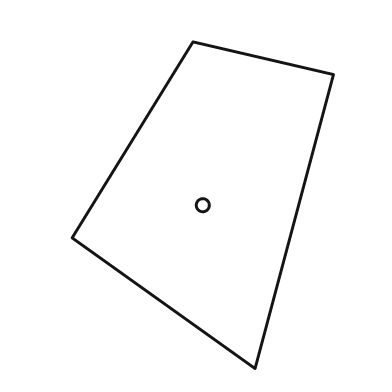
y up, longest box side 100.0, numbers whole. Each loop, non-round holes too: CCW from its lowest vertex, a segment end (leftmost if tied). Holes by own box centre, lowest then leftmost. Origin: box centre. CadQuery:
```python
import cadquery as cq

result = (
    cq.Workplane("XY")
    .moveTo(16.0, -50.0)
    .lineTo(40.0, 40.0)
    .lineTo(-3.0, 50.0)
    .lineTo(-40.0, -10.0)
    .close()
    .moveTo(0.0, 0.0)
    .circle(2.0)
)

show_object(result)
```